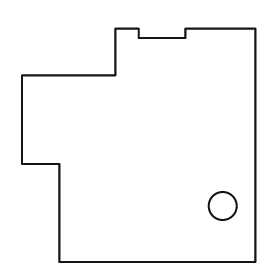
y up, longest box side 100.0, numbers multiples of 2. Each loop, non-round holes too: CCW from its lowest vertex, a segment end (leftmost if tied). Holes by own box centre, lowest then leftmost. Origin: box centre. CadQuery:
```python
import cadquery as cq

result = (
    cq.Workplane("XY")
    .moveTo(-34.0, -50.0)
    .lineTo(50.0, -50.0)
    .lineTo(50.0, 50.0)
    .lineTo(20.0, 50.0)
    .lineTo(20.0, 46.0)
    .lineTo(0.0, 46.0)
    .lineTo(0.0, 50.0)
    .lineTo(-10.0, 50.0)
    .lineTo(-10.0, 30.0)
    .lineTo(-50.0, 30.0)
    .lineTo(-50.0, -8.0)
    .lineTo(-34.0, -8.0)
    .close()
    .moveTo(36.0, -26.0)
    .circle(6.0)
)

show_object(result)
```